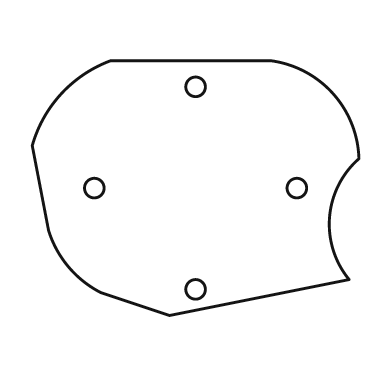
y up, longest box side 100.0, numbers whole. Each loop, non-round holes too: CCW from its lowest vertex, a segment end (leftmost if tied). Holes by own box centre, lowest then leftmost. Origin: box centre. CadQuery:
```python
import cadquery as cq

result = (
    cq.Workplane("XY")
    .moveTo(-8.0, -39.0)
    .lineTo(47.0, -28.0)
    .threePointArc((41.0, -9.0), (50.0, 9.0))
    .threePointArc((42.0, 29.0), (23.0, 39.0))
    .lineTo(-26.0, 39.0)
    .threePointArc((-41.0, 29.0), (-50.0, 13.0))
    .lineTo(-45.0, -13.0)
    .threePointArc((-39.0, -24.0), (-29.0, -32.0))
    .close()
    .moveTo(0.0, -31.0)
    .circle(3.0)
    .moveTo(-31.0, 0.0)
    .circle(3.0)
    .moveTo(31.0, 0.0)
    .circle(3.0)
    .moveTo(0.0, 31.0)
    .circle(3.0)
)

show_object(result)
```